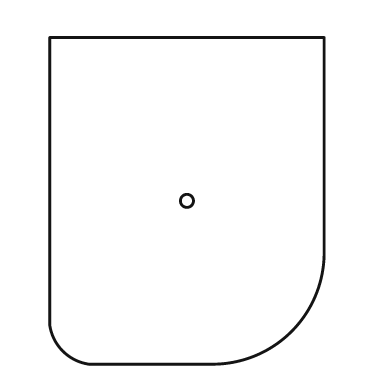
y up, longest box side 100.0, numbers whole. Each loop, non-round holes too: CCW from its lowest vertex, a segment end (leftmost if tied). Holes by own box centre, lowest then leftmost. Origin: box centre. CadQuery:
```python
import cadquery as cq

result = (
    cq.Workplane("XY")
    .moveTo(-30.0, -50.0)
    .lineTo(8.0, -50.0)
    .threePointArc((32.0, -40.0), (42.0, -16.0))
    .lineTo(42.0, 50.0)
    .lineTo(-42.0, 50.0)
    .lineTo(-42.0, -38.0)
    .threePointArc((-38.0, -46.0), (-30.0, -50.0))
    .close()
    .moveTo(0.0, 0.0)
    .circle(2.0)
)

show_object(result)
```